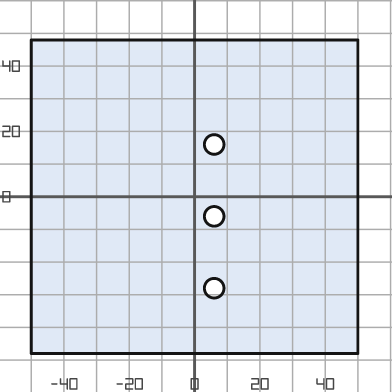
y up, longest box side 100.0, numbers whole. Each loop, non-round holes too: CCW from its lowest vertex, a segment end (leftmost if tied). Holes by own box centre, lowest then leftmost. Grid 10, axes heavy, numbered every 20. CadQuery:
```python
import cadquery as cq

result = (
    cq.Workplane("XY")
    .moveTo(-50.0, -48.0)
    .lineTo(50.0, -48.0)
    .lineTo(50.0, 48.0)
    .lineTo(-50.0, 48.0)
    .close()
    .moveTo(6.0, -28.0)
    .circle(3.0)
    .moveTo(6.0, -6.0)
    .circle(3.0)
    .moveTo(6.0, 16.0)
    .circle(3.0)
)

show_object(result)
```